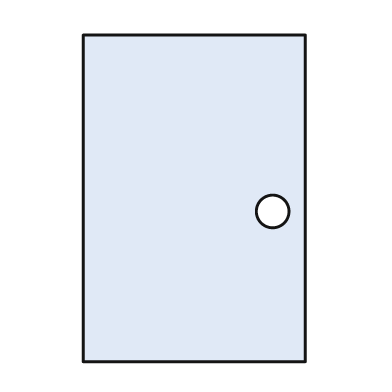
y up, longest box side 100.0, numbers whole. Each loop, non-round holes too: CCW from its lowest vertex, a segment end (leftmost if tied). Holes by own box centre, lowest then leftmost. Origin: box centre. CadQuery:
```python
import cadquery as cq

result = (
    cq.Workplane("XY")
    .moveTo(-34.0, -50.0)
    .lineTo(34.0, -50.0)
    .lineTo(34.0, 50.0)
    .lineTo(-34.0, 50.0)
    .close()
    .moveTo(24.0, -4.0)
    .circle(5.0)
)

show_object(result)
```